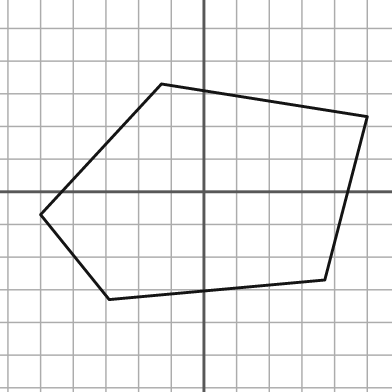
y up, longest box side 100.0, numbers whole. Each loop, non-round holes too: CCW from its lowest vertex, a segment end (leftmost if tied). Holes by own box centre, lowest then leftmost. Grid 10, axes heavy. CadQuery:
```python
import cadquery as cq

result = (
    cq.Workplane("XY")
    .moveTo(-29.0, -33.0)
    .lineTo(37.0, -27.0)
    .lineTo(50.0, 23.0)
    .lineTo(-13.0, 33.0)
    .lineTo(-50.0, -7.0)
    .close()
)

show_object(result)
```